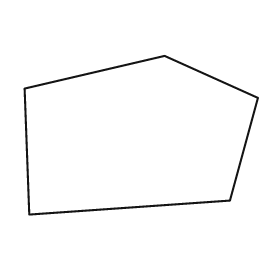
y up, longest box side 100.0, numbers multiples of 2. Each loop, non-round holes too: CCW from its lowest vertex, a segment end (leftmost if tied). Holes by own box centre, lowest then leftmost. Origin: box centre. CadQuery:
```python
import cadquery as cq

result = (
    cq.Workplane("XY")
    .moveTo(-48.0, -34.0)
    .lineTo(38.0, -28.0)
    .lineTo(50.0, 16.0)
    .lineTo(10.0, 34.0)
    .lineTo(-50.0, 20.0)
    .close()
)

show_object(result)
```